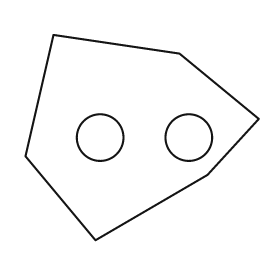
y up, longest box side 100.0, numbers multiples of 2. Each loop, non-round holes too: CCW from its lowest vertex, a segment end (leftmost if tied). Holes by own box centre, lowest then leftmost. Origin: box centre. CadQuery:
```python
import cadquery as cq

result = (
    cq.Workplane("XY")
    .moveTo(-20.0, -44.0)
    .lineTo(28.0, -16.0)
    .lineTo(50.0, 8.0)
    .lineTo(16.0, 36.0)
    .lineTo(-38.0, 44.0)
    .lineTo(-50.0, -8.0)
    .close()
    .moveTo(-18.0, 0.0)
    .circle(10.0)
    .moveTo(20.0, 0.0)
    .circle(10.0)
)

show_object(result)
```